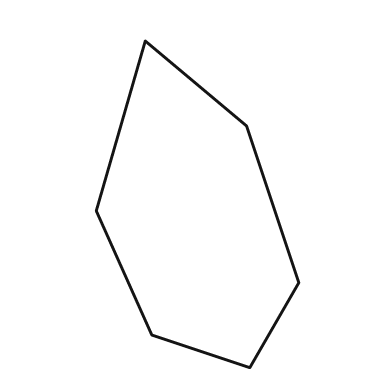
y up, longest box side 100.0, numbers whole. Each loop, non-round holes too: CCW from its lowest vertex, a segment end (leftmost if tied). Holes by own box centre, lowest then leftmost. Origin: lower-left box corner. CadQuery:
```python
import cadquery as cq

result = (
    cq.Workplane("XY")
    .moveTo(47.0, 0.0)
    .lineTo(62.0, 26.0)
    .lineTo(46.0, 74.0)
    .lineTo(15.0, 100.0)
    .lineTo(0.0, 48.0)
    .lineTo(17.0, 10.0)
    .close()
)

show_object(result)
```